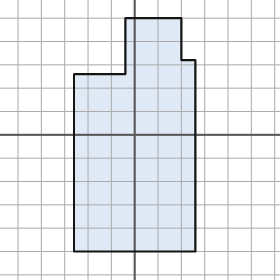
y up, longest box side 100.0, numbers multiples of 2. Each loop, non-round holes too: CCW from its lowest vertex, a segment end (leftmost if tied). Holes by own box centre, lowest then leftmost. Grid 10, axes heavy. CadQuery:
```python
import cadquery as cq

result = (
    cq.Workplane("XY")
    .moveTo(-26.0, -50.0)
    .lineTo(26.0, -50.0)
    .lineTo(26.0, 32.0)
    .lineTo(20.0, 32.0)
    .lineTo(20.0, 50.0)
    .lineTo(-4.0, 50.0)
    .lineTo(-4.0, 26.0)
    .lineTo(-26.0, 26.0)
    .close()
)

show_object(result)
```